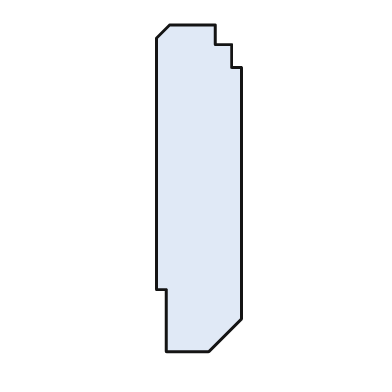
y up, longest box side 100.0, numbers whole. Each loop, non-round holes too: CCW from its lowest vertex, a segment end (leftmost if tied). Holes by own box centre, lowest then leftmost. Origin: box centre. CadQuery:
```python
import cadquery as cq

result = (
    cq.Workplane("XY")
    .moveTo(-10.0, -50.0)
    .lineTo(3.0, -50.0)
    .lineTo(13.0, -40.0)
    .lineTo(13.0, 37.0)
    .lineTo(10.0, 37.0)
    .lineTo(10.0, 44.0)
    .lineTo(5.0, 44.0)
    .lineTo(5.0, 50.0)
    .lineTo(-9.0, 50.0)
    .lineTo(-13.0, 46.0)
    .lineTo(-13.0, -31.0)
    .lineTo(-10.0, -31.0)
    .close()
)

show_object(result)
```